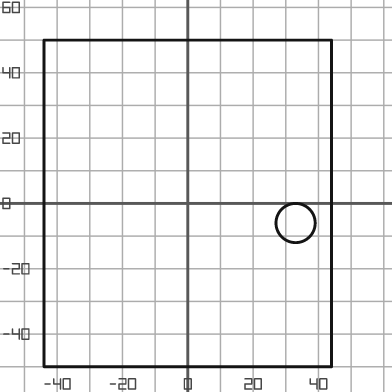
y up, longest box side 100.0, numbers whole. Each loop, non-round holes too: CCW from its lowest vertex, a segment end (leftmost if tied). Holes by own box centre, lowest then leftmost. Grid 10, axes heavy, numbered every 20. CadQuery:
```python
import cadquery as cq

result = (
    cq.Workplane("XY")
    .moveTo(-44.0, -50.0)
    .lineTo(44.0, -50.0)
    .lineTo(44.0, 50.0)
    .lineTo(-44.0, 50.0)
    .close()
    .moveTo(33.0, -6.0)
    .circle(6.0)
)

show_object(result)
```